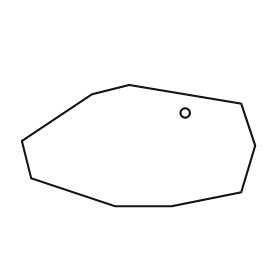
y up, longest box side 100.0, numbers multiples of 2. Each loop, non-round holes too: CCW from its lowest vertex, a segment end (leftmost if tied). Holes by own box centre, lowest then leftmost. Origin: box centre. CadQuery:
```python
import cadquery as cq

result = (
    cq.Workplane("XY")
    .moveTo(-10.0, -26.0)
    .lineTo(14.0, -26.0)
    .lineTo(44.0, -20.0)
    .lineTo(50.0, 0.0)
    .lineTo(44.0, 18.0)
    .lineTo(-4.0, 26.0)
    .lineTo(-20.0, 22.0)
    .lineTo(-50.0, 2.0)
    .lineTo(-46.0, -14.0)
    .close()
    .moveTo(20.0, 14.0)
    .circle(2.0)
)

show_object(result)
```